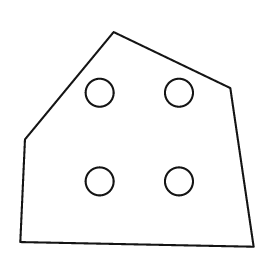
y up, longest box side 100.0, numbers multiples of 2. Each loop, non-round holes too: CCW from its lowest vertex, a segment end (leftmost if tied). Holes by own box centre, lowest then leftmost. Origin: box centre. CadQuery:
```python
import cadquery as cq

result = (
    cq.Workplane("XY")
    .moveTo(50.0, -46.0)
    .lineTo(40.0, 22.0)
    .lineTo(-10.0, 46.0)
    .lineTo(-48.0, 0.0)
    .lineTo(-50.0, -44.0)
    .close()
    .moveTo(-16.0, -18.0)
    .circle(6.0)
    .moveTo(18.0, -18.0)
    .circle(6.0)
    .moveTo(-16.0, 20.0)
    .circle(6.0)
    .moveTo(18.0, 20.0)
    .circle(6.0)
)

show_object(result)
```